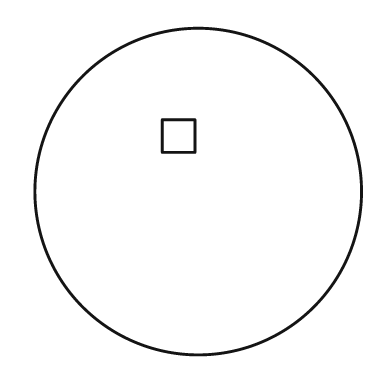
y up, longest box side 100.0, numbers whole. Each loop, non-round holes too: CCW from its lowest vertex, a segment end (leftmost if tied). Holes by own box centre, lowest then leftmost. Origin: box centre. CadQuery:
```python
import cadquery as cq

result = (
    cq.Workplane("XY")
    .moveTo(0.0, 0.0)
    .circle(50.0)
    .moveTo(-11.0, 12.0)
    .lineTo(-1.0, 12.0)
    .lineTo(-1.0, 22.0)
    .lineTo(-11.0, 22.0)
    .close()
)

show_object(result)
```